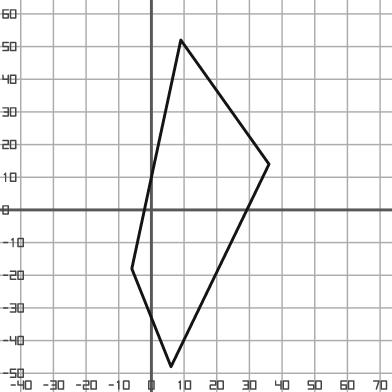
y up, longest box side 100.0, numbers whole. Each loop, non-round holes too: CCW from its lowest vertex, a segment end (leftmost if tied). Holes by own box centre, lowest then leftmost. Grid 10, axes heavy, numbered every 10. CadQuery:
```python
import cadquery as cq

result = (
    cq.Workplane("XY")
    .moveTo(6.0, -48.0)
    .lineTo(36.0, 14.0)
    .lineTo(9.0, 52.0)
    .lineTo(-6.0, -18.0)
    .close()
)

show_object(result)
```